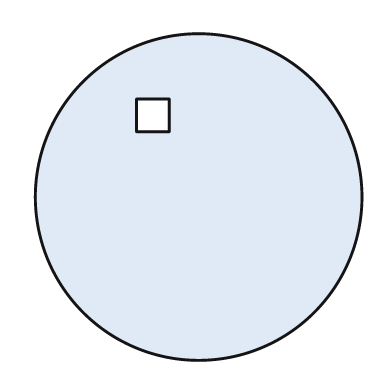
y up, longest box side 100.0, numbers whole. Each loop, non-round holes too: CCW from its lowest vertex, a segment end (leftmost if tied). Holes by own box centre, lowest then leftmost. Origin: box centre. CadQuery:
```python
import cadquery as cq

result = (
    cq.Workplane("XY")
    .moveTo(0.0, 0.0)
    .circle(50.0)
    .moveTo(-19.0, 20.0)
    .lineTo(-9.0, 20.0)
    .lineTo(-9.0, 30.0)
    .lineTo(-19.0, 30.0)
    .close()
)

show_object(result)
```